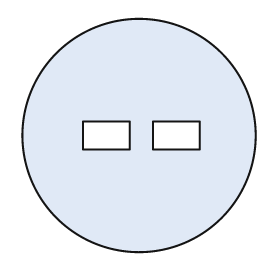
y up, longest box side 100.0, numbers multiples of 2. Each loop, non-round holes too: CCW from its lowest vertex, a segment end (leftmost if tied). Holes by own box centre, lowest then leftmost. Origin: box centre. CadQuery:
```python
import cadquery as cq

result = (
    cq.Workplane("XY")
    .moveTo(0.0, 0.0)
    .circle(50.0)
    .moveTo(-24.0, -6.0)
    .lineTo(-4.0, -6.0)
    .lineTo(-4.0, 6.0)
    .lineTo(-24.0, 6.0)
    .close()
    .moveTo(6.0, -6.0)
    .lineTo(26.0, -6.0)
    .lineTo(26.0, 6.0)
    .lineTo(6.0, 6.0)
    .close()
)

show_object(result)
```